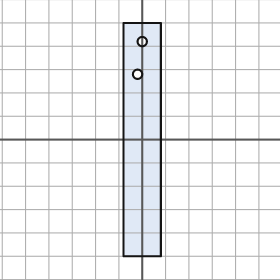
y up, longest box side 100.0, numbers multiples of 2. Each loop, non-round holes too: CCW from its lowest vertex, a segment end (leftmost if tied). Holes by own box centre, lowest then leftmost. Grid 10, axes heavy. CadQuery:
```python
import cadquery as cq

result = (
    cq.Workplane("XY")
    .moveTo(-8.0, -50.0)
    .lineTo(8.0, -50.0)
    .lineTo(8.0, 50.0)
    .lineTo(-8.0, 50.0)
    .close()
    .moveTo(-2.0, 28.0)
    .circle(2.0)
    .moveTo(0.0, 42.0)
    .circle(2.0)
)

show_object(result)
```